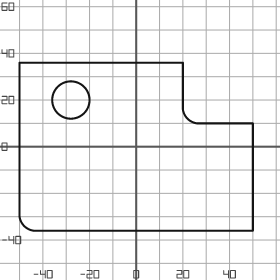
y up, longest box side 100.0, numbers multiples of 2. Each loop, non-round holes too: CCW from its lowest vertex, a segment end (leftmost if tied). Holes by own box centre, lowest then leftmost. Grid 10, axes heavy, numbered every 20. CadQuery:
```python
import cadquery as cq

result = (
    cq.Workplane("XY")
    .moveTo(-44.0, -36.0)
    .lineTo(50.0, -36.0)
    .lineTo(50.0, 10.0)
    .lineTo(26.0, 10.0)
    .threePointArc((22.0, 12.0), (20.0, 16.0))
    .lineTo(20.0, 36.0)
    .lineTo(-50.0, 36.0)
    .lineTo(-50.0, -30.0)
    .threePointArc((-48.0, -34.0), (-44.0, -36.0))
    .close()
    .moveTo(-28.0, 20.0)
    .circle(8.0)
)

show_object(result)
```